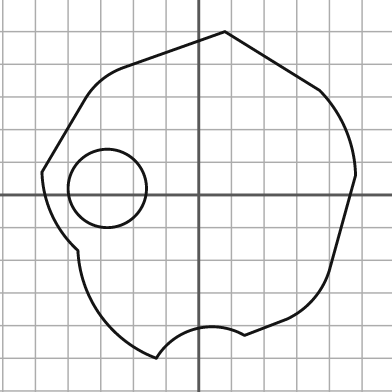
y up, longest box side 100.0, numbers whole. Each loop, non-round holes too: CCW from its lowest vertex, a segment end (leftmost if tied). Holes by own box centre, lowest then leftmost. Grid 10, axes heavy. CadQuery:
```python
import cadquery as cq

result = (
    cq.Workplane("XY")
    .moveTo(-13.0, -50.0)
    .threePointArc((-1.0, -41.0), (14.0, -43.0))
    .lineTo(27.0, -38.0)
    .threePointArc((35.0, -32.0), (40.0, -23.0))
    .lineTo(48.0, 6.0)
    .threePointArc((45.0, 20.0), (37.0, 32.0))
    .lineTo(8.0, 50.0)
    .lineTo(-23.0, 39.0)
    .threePointArc((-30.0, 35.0), (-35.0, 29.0))
    .lineTo(-48.0, 7.0)
    .threePointArc((-45.0, -6.0), (-37.0, -17.0))
    .threePointArc((-30.0, -37.0), (-13.0, -50.0))
    .close()
    .moveTo(-28.0, 2.0)
    .circle(12.0)
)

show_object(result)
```